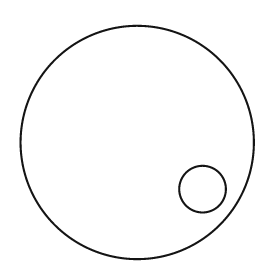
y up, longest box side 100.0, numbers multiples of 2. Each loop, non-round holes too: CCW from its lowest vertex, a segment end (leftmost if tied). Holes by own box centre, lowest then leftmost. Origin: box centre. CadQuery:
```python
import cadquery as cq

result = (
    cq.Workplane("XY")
    .moveTo(0.0, 0.0)
    .circle(50.0)
    .moveTo(28.0, -20.0)
    .circle(10.0)
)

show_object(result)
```